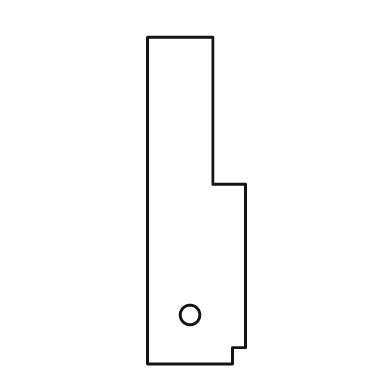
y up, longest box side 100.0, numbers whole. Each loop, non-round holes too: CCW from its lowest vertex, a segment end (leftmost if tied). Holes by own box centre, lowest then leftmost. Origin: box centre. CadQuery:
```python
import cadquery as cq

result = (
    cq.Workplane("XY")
    .moveTo(-15.0, -50.0)
    .lineTo(11.0, -50.0)
    .lineTo(11.0, -45.0)
    .lineTo(15.0, -45.0)
    .lineTo(15.0, 5.0)
    .lineTo(5.0, 5.0)
    .lineTo(5.0, 50.0)
    .lineTo(-15.0, 50.0)
    .close()
    .moveTo(-2.0, -35.0)
    .circle(3.0)
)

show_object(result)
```